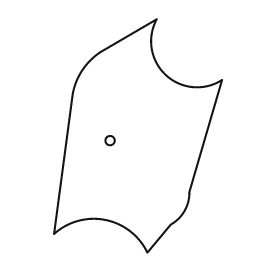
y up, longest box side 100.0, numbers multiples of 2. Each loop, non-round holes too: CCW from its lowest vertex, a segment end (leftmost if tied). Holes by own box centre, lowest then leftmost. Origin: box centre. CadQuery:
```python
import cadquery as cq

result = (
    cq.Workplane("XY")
    .moveTo(4.0, -50.0)
    .lineTo(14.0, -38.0)
    .threePointArc((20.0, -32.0), (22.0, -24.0))
    .lineTo(36.0, 24.0)
    .threePointArc((12.0, 26.0), (8.0, 50.0))
    .lineTo(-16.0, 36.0)
    .threePointArc((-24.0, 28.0), (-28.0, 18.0))
    .lineTo(-36.0, -42.0)
    .threePointArc((-14.0, -36.0), (4.0, -50.0))
    .close()
    .moveTo(-12.0, -2.0)
    .circle(2.0)
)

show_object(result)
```